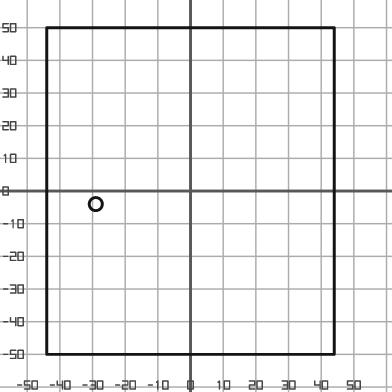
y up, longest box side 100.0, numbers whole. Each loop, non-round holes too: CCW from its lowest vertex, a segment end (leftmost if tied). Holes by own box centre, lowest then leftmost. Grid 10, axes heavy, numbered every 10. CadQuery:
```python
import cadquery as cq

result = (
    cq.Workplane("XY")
    .moveTo(-44.0, -50.0)
    .lineTo(44.0, -50.0)
    .lineTo(44.0, 50.0)
    .lineTo(-44.0, 50.0)
    .close()
    .moveTo(-29.0, -4.0)
    .circle(2.0)
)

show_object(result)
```